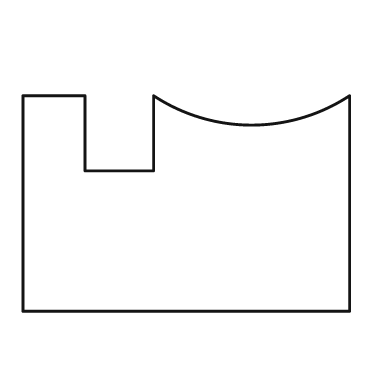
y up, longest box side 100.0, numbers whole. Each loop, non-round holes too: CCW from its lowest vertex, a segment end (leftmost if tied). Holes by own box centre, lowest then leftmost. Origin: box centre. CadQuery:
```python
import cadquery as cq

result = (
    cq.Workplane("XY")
    .moveTo(-50.0, -33.0)
    .lineTo(50.0, -33.0)
    .lineTo(50.0, 33.0)
    .threePointArc((20.0, 24.0), (-10.0, 33.0))
    .lineTo(-10.0, 10.0)
    .lineTo(-31.0, 10.0)
    .lineTo(-31.0, 33.0)
    .lineTo(-50.0, 33.0)
    .close()
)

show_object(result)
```